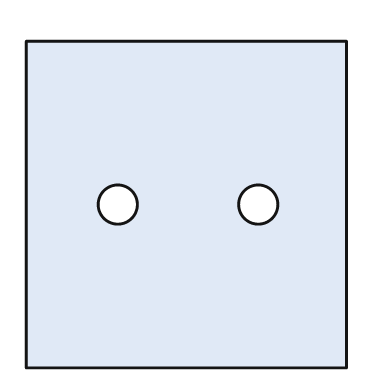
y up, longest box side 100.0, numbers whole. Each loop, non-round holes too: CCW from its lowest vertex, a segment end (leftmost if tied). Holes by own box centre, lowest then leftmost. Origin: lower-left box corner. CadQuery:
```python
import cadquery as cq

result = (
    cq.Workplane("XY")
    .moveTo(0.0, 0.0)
    .lineTo(98.0, 0.0)
    .lineTo(98.0, 100.0)
    .lineTo(0.0, 100.0)
    .close()
    .moveTo(28.0, 50.0)
    .circle(6.0)
    .moveTo(71.0, 50.0)
    .circle(6.0)
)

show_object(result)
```